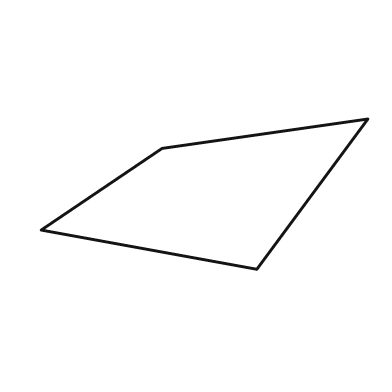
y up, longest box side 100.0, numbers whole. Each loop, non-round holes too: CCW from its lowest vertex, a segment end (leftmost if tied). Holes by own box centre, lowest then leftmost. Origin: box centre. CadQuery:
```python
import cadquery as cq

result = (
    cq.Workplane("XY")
    .moveTo(16.0, -23.0)
    .lineTo(50.0, 23.0)
    .lineTo(-13.0, 14.0)
    .lineTo(-50.0, -11.0)
    .close()
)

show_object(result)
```